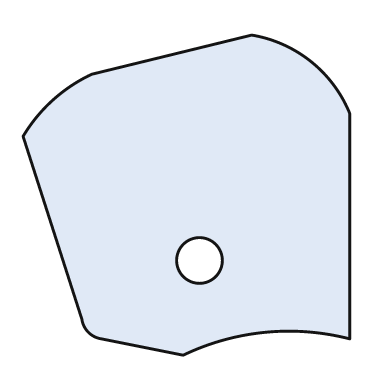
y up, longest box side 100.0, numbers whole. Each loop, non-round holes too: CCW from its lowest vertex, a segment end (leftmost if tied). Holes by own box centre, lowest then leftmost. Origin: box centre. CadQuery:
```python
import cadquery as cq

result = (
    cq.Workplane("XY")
    .moveTo(-1.0, -49.0)
    .threePointArc((24.0, -42.0), (50.0, -44.0))
    .lineTo(50.0, 25.0)
    .threePointArc((38.0, 41.0), (20.0, 49.0))
    .lineTo(-29.0, 37.0)
    .threePointArc((-41.0, 29.0), (-50.0, 18.0))
    .lineTo(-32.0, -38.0)
    .threePointArc((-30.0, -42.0), (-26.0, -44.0))
    .close()
    .moveTo(4.0, -20.0)
    .circle(7.0)
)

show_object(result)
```